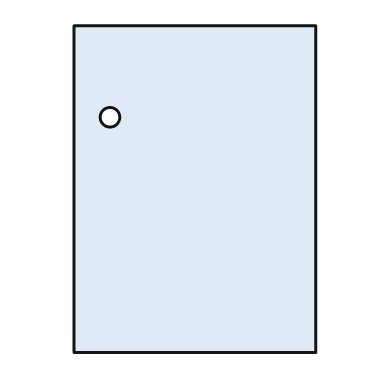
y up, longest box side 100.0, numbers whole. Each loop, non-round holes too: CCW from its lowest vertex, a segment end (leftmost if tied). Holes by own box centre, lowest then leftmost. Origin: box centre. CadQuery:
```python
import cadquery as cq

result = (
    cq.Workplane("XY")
    .moveTo(-37.0, -50.0)
    .lineTo(37.0, -50.0)
    .lineTo(37.0, 50.0)
    .lineTo(-37.0, 50.0)
    .close()
    .moveTo(-26.0, 22.0)
    .circle(3.0)
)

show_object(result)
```